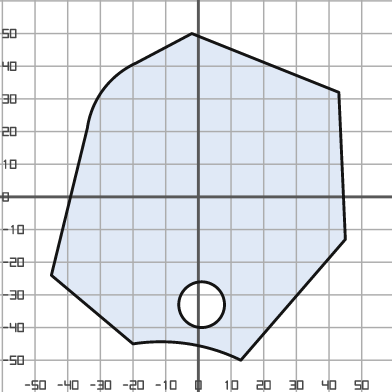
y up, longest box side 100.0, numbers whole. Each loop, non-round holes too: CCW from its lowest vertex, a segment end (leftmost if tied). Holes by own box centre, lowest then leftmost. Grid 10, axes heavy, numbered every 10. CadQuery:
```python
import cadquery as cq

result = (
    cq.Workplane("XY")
    .moveTo(13.0, -50.0)
    .lineTo(45.0, -13.0)
    .lineTo(43.0, 32.0)
    .lineTo(-2.0, 50.0)
    .lineTo(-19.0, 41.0)
    .threePointArc((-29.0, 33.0), (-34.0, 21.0))
    .lineTo(-45.0, -24.0)
    .lineTo(-20.0, -45.0)
    .threePointArc((-3.0, -45.0), (13.0, -50.0))
    .close()
    .moveTo(1.0, -33.0)
    .circle(7.0)
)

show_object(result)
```